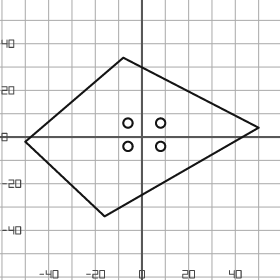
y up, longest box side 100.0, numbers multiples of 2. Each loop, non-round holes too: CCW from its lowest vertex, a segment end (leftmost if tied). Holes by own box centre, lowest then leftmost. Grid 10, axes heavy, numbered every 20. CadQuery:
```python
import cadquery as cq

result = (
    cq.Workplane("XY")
    .moveTo(-16.0, -34.0)
    .lineTo(50.0, 4.0)
    .lineTo(-8.0, 34.0)
    .lineTo(-50.0, -2.0)
    .close()
    .moveTo(-6.0, -4.0)
    .circle(2.0)
    .moveTo(8.0, -4.0)
    .circle(2.0)
    .moveTo(-6.0, 6.0)
    .circle(2.0)
    .moveTo(8.0, 6.0)
    .circle(2.0)
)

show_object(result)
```